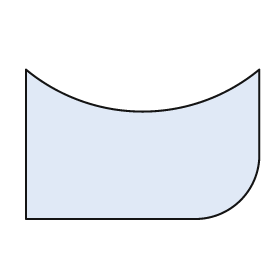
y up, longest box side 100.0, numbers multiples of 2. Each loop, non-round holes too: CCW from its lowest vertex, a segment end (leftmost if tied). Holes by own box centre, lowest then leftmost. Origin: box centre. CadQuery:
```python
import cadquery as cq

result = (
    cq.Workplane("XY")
    .moveTo(-50.0, -32.0)
    .lineTo(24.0, -32.0)
    .threePointArc((42.0, -24.0), (50.0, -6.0))
    .lineTo(50.0, 32.0)
    .threePointArc((0.0, 14.0), (-50.0, 32.0))
    .close()
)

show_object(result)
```